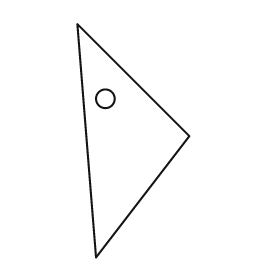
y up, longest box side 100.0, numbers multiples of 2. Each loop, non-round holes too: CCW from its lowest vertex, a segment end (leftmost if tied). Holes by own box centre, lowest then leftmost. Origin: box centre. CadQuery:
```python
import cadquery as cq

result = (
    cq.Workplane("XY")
    .moveTo(-16.0, -50.0)
    .lineTo(24.0, 2.0)
    .lineTo(-24.0, 50.0)
    .close()
    .moveTo(-12.0, 18.0)
    .circle(4.0)
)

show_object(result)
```